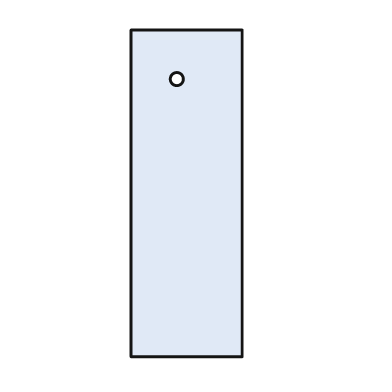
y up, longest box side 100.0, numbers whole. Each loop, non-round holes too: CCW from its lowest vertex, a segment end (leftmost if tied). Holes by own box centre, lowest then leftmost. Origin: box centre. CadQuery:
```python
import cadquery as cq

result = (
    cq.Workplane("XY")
    .moveTo(-17.0, -50.0)
    .lineTo(17.0, -50.0)
    .lineTo(17.0, 50.0)
    .lineTo(-17.0, 50.0)
    .close()
    .moveTo(-3.0, 35.0)
    .circle(2.0)
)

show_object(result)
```